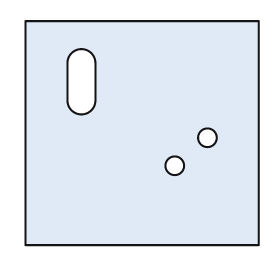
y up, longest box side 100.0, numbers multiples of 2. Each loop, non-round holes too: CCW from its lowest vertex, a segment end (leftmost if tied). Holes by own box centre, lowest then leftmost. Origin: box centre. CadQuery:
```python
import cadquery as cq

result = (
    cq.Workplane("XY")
    .moveTo(-50.0, -48.0)
    .lineTo(50.0, -48.0)
    .lineTo(50.0, 48.0)
    .lineTo(-50.0, 48.0)
    .close()
    .moveTo(14.0, -14.0)
    .circle(4.0)
    .moveTo(28.0, -2.0)
    .circle(4.0)
    .moveTo(-32.0, 14.0)
    .threePointArc((-26.0, 8.0), (-20.0, 14.0))
    .lineTo(-20.0, 30.0)
    .threePointArc((-26.0, 36.0), (-32.0, 30.0))
    .close()
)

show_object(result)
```